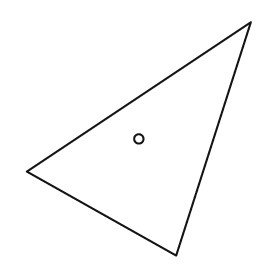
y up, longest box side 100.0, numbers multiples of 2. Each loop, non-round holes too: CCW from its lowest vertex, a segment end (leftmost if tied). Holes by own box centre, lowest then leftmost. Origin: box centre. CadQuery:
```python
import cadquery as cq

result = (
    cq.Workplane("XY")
    .moveTo(16.0, -50.0)
    .lineTo(48.0, 50.0)
    .lineTo(-48.0, -14.0)
    .close()
    .moveTo(0.0, 0.0)
    .circle(2.0)
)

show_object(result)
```